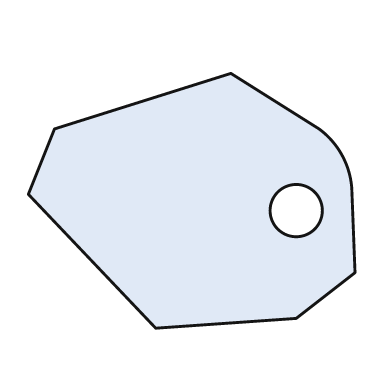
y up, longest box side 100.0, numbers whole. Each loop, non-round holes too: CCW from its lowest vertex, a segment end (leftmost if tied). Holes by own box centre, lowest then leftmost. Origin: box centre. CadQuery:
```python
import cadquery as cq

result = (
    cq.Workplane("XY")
    .moveTo(-11.0, -39.0)
    .lineTo(32.0, -36.0)
    .lineTo(50.0, -22.0)
    .lineTo(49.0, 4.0)
    .threePointArc((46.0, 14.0), (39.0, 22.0))
    .lineTo(12.0, 39.0)
    .lineTo(-42.0, 22.0)
    .lineTo(-50.0, 2.0)
    .close()
    .moveTo(32.0, -3.0)
    .circle(8.0)
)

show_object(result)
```